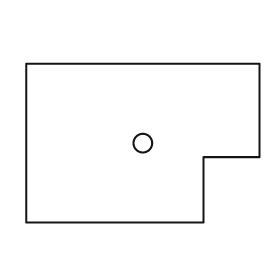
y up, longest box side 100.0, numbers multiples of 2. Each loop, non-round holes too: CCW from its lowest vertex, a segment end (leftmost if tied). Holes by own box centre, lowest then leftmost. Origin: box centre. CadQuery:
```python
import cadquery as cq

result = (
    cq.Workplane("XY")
    .moveTo(-50.0, -34.0)
    .lineTo(26.0, -34.0)
    .lineTo(26.0, -6.0)
    .lineTo(50.0, -6.0)
    .lineTo(50.0, 34.0)
    .lineTo(-50.0, 34.0)
    .close()
    .moveTo(0.0, 0.0)
    .circle(4.0)
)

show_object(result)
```